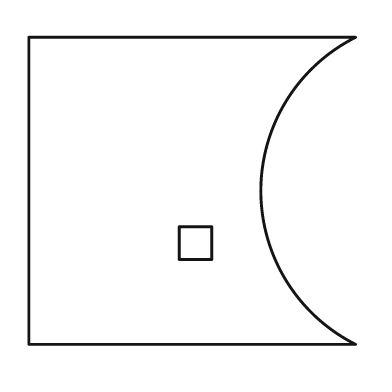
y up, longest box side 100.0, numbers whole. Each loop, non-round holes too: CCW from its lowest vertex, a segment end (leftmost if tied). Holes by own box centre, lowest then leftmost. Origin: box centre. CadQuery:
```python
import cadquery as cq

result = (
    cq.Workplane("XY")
    .moveTo(-50.0, -47.0)
    .lineTo(50.0, -47.0)
    .threePointArc((21.0, 0.0), (50.0, 47.0))
    .lineTo(-50.0, 47.0)
    .close()
    .moveTo(-4.0, -21.0)
    .lineTo(6.0, -21.0)
    .lineTo(6.0, -11.0)
    .lineTo(-4.0, -11.0)
    .close()
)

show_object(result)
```